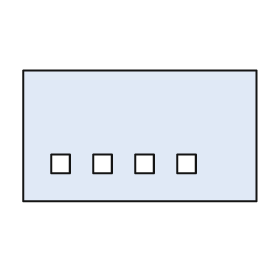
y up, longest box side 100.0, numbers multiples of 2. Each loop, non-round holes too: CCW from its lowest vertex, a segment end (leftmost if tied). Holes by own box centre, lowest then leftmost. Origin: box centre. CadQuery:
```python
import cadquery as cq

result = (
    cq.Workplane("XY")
    .moveTo(-50.0, -28.0)
    .lineTo(50.0, -28.0)
    .lineTo(50.0, 28.0)
    .lineTo(-50.0, 28.0)
    .close()
    .moveTo(-38.0, -16.0)
    .lineTo(-30.0, -16.0)
    .lineTo(-30.0, -8.0)
    .lineTo(-38.0, -8.0)
    .close()
    .moveTo(-20.0, -16.0)
    .lineTo(-12.0, -16.0)
    .lineTo(-12.0, -8.0)
    .lineTo(-20.0, -8.0)
    .close()
    .moveTo(-2.0, -16.0)
    .lineTo(6.0, -16.0)
    .lineTo(6.0, -8.0)
    .lineTo(-2.0, -8.0)
    .close()
    .moveTo(16.0, -16.0)
    .lineTo(24.0, -16.0)
    .lineTo(24.0, -8.0)
    .lineTo(16.0, -8.0)
    .close()
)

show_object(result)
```